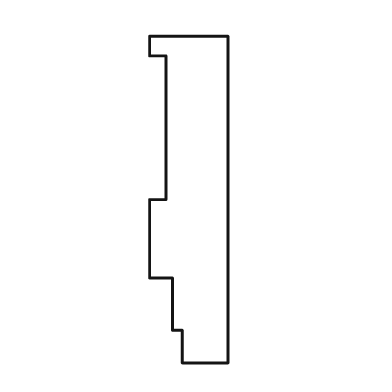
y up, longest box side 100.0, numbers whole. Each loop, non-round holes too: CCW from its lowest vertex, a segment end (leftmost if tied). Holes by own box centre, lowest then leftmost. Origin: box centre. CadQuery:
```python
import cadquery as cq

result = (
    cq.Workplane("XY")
    .moveTo(-2.0, -50.0)
    .lineTo(12.0, -50.0)
    .lineTo(12.0, 50.0)
    .lineTo(-12.0, 50.0)
    .lineTo(-12.0, 44.0)
    .lineTo(-7.0, 44.0)
    .lineTo(-7.0, 0.0)
    .lineTo(-12.0, 0.0)
    .lineTo(-12.0, -24.0)
    .lineTo(-5.0, -24.0)
    .lineTo(-5.0, -40.0)
    .lineTo(-2.0, -40.0)
    .close()
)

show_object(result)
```